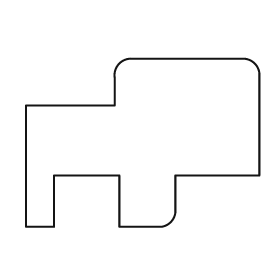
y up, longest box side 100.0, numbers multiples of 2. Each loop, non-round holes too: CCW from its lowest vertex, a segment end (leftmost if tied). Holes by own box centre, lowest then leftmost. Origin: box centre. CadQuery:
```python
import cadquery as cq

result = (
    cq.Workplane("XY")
    .moveTo(-50.0, -36.0)
    .lineTo(-38.0, -36.0)
    .lineTo(-38.0, -14.0)
    .lineTo(-10.0, -14.0)
    .lineTo(-10.0, -36.0)
    .lineTo(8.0, -36.0)
    .threePointArc((12.0, -34.0), (14.0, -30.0))
    .lineTo(14.0, -14.0)
    .lineTo(50.0, -14.0)
    .lineTo(50.0, 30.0)
    .threePointArc((48.0, 34.0), (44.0, 36.0))
    .lineTo(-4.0, 36.0)
    .threePointArc((-10.0, 34.0), (-12.0, 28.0))
    .lineTo(-12.0, 16.0)
    .lineTo(-50.0, 16.0)
    .close()
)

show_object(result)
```